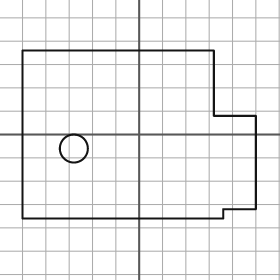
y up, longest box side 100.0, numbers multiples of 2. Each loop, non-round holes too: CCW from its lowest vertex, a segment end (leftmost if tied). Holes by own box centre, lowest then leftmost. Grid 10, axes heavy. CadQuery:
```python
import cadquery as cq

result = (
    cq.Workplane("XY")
    .moveTo(-50.0, -36.0)
    .lineTo(36.0, -36.0)
    .lineTo(36.0, -32.0)
    .lineTo(50.0, -32.0)
    .lineTo(50.0, 8.0)
    .lineTo(32.0, 8.0)
    .lineTo(32.0, 36.0)
    .lineTo(-50.0, 36.0)
    .close()
    .moveTo(-28.0, -6.0)
    .circle(6.0)
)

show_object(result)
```